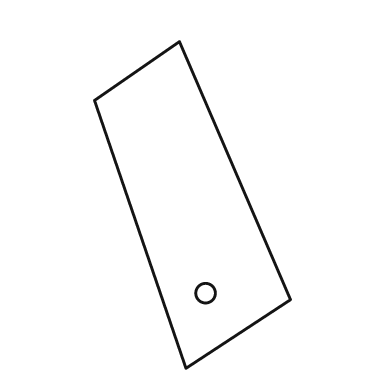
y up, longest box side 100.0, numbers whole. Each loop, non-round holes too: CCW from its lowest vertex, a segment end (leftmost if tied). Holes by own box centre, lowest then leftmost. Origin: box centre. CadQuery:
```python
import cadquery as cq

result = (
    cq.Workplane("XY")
    .moveTo(-2.0, -50.0)
    .lineTo(30.0, -29.0)
    .lineTo(-4.0, 50.0)
    .lineTo(-30.0, 32.0)
    .close()
    .moveTo(4.0, -27.0)
    .circle(3.0)
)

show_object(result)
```